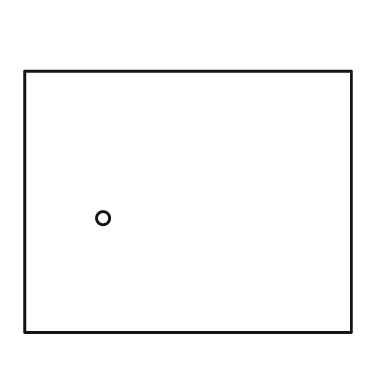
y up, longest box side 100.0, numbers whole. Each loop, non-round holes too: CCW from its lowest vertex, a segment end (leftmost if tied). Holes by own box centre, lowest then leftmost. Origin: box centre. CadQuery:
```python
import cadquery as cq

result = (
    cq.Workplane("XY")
    .moveTo(-50.0, -40.0)
    .lineTo(50.0, -40.0)
    .lineTo(50.0, 40.0)
    .lineTo(-50.0, 40.0)
    .close()
    .moveTo(-26.0, -5.0)
    .circle(2.0)
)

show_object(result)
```